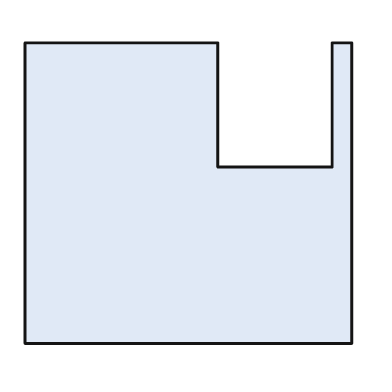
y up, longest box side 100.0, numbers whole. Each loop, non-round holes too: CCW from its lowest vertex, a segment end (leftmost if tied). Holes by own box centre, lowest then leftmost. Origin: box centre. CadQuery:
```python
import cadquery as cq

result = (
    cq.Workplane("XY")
    .moveTo(-50.0, -46.0)
    .lineTo(50.0, -46.0)
    .lineTo(50.0, 46.0)
    .lineTo(44.0, 46.0)
    .lineTo(44.0, 8.0)
    .lineTo(9.0, 8.0)
    .lineTo(9.0, 46.0)
    .lineTo(-50.0, 46.0)
    .close()
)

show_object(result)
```